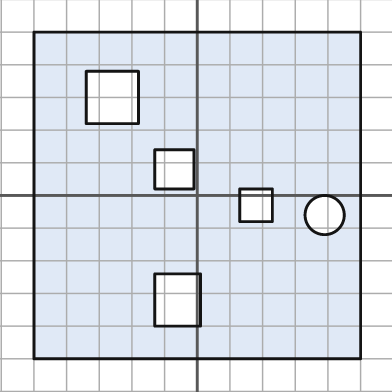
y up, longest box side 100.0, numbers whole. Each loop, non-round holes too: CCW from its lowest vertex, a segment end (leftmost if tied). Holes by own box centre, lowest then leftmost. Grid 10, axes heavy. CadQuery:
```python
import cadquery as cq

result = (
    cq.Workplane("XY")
    .moveTo(-50.0, -50.0)
    .lineTo(50.0, -50.0)
    .lineTo(50.0, 50.0)
    .lineTo(-50.0, 50.0)
    .close()
    .moveTo(-13.0, -40.0)
    .lineTo(1.0, -40.0)
    .lineTo(1.0, -24.0)
    .lineTo(-13.0, -24.0)
    .close()
    .moveTo(39.0, -6.0)
    .circle(6.0)
    .moveTo(13.0, -8.0)
    .lineTo(23.0, -8.0)
    .lineTo(23.0, 2.0)
    .lineTo(13.0, 2.0)
    .close()
    .moveTo(-13.0, 2.0)
    .lineTo(-1.0, 2.0)
    .lineTo(-1.0, 14.0)
    .lineTo(-13.0, 14.0)
    .close()
    .moveTo(-34.0, 22.0)
    .lineTo(-18.0, 22.0)
    .lineTo(-18.0, 38.0)
    .lineTo(-34.0, 38.0)
    .close()
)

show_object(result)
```